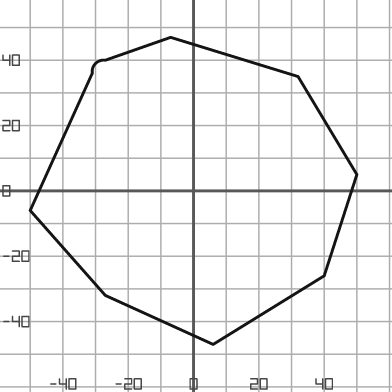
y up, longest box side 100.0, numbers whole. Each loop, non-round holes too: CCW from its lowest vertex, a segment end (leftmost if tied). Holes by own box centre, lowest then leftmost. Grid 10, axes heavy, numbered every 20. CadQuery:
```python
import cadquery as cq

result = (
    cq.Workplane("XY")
    .moveTo(6.0, -47.0)
    .lineTo(40.0, -26.0)
    .lineTo(50.0, 5.0)
    .lineTo(32.0, 35.0)
    .lineTo(-7.0, 47.0)
    .lineTo(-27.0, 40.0)
    .threePointArc((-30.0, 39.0), (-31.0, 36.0))
    .lineTo(-50.0, -6.0)
    .lineTo(-27.0, -32.0)
    .close()
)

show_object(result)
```